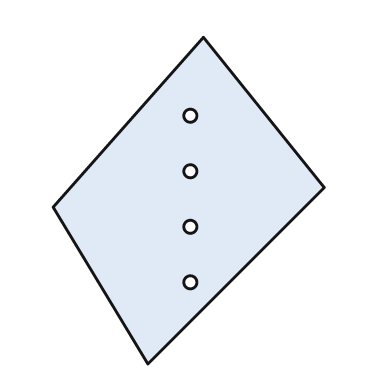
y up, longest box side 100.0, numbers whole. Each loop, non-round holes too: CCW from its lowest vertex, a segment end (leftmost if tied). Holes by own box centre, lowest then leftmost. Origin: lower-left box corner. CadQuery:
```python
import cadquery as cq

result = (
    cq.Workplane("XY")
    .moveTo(29.0, 0.0)
    .lineTo(83.0, 54.0)
    .lineTo(46.0, 100.0)
    .lineTo(0.0, 48.0)
    .close()
    .moveTo(42.0, 25.0)
    .circle(2.0)
    .moveTo(42.0, 42.0)
    .circle(2.0)
    .moveTo(42.0, 59.0)
    .circle(2.0)
    .moveTo(42.0, 76.0)
    .circle(2.0)
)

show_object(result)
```